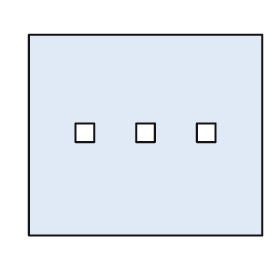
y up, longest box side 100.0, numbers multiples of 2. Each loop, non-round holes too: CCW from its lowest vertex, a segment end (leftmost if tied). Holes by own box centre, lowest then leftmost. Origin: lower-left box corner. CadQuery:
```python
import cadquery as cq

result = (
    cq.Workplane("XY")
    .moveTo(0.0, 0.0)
    .lineTo(100.0, 0.0)
    .lineTo(100.0, 86.0)
    .lineTo(0.0, 86.0)
    .close()
    .moveTo(20.0, 40.0)
    .lineTo(28.0, 40.0)
    .lineTo(28.0, 48.0)
    .lineTo(20.0, 48.0)
    .close()
    .moveTo(46.0, 40.0)
    .lineTo(54.0, 40.0)
    .lineTo(54.0, 48.0)
    .lineTo(46.0, 48.0)
    .close()
    .moveTo(72.0, 40.0)
    .lineTo(80.0, 40.0)
    .lineTo(80.0, 48.0)
    .lineTo(72.0, 48.0)
    .close()
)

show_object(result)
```